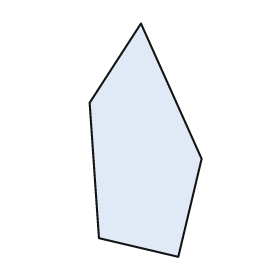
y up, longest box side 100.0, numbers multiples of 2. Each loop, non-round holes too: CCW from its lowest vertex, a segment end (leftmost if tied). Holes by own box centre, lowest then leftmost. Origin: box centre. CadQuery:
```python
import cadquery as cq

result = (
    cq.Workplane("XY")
    .moveTo(14.0, -50.0)
    .lineTo(24.0, -8.0)
    .lineTo(-2.0, 50.0)
    .lineTo(-24.0, 16.0)
    .lineTo(-20.0, -42.0)
    .close()
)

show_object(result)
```